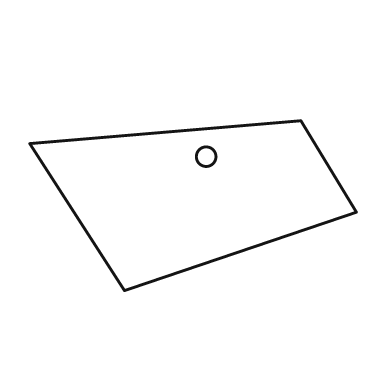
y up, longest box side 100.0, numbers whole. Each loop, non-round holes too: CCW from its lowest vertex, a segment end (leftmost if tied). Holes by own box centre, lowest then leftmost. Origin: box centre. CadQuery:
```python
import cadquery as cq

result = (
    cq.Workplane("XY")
    .moveTo(-21.0, -26.0)
    .lineTo(50.0, -2.0)
    .lineTo(33.0, 26.0)
    .lineTo(-50.0, 19.0)
    .close()
    .moveTo(4.0, 15.0)
    .circle(3.0)
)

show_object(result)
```